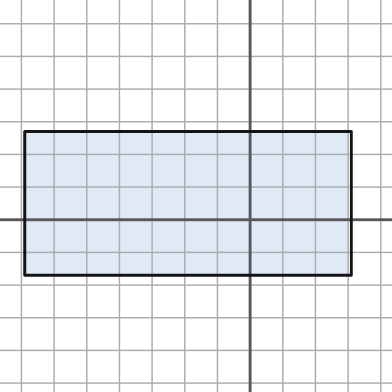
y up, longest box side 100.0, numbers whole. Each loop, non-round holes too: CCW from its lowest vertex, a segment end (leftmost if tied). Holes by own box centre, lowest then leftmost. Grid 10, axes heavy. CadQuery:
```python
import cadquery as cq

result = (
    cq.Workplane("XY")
    .moveTo(-69.0, -17.0)
    .lineTo(31.0, -17.0)
    .lineTo(31.0, 27.0)
    .lineTo(-69.0, 27.0)
    .close()
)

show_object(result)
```